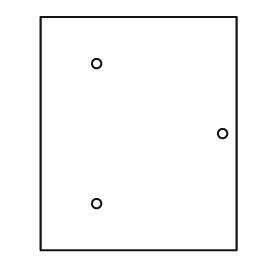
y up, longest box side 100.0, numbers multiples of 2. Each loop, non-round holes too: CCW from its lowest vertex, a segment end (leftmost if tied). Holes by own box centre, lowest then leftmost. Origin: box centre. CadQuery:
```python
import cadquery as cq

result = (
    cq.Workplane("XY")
    .moveTo(-42.0, -50.0)
    .lineTo(42.0, -50.0)
    .lineTo(42.0, 50.0)
    .lineTo(-42.0, 50.0)
    .close()
    .moveTo(-18.0, -30.0)
    .circle(2.0)
    .moveTo(36.0, 0.0)
    .circle(2.0)
    .moveTo(-18.0, 30.0)
    .circle(2.0)
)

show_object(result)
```